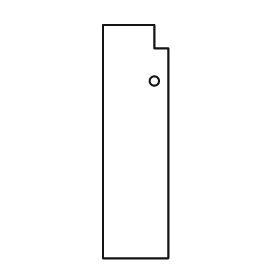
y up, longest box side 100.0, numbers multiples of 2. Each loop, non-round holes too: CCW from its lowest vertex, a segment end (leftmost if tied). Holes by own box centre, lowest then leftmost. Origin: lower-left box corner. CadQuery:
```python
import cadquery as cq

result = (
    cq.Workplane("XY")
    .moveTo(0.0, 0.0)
    .lineTo(28.0, 0.0)
    .lineTo(28.0, 90.0)
    .lineTo(22.0, 90.0)
    .lineTo(22.0, 100.0)
    .lineTo(0.0, 100.0)
    .close()
    .moveTo(22.0, 76.0)
    .circle(2.0)
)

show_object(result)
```